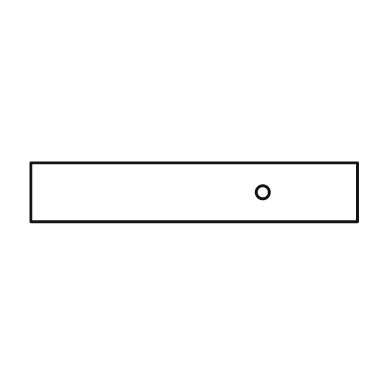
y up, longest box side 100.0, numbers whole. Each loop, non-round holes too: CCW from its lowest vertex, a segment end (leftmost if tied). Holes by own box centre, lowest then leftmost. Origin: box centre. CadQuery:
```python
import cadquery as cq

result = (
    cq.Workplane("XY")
    .moveTo(-50.0, -9.0)
    .lineTo(50.0, -9.0)
    .lineTo(50.0, 9.0)
    .lineTo(-50.0, 9.0)
    .close()
    .moveTo(21.0, 0.0)
    .circle(2.0)
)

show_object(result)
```